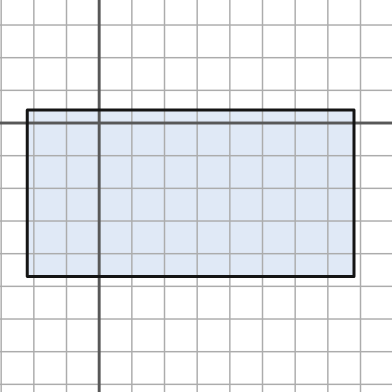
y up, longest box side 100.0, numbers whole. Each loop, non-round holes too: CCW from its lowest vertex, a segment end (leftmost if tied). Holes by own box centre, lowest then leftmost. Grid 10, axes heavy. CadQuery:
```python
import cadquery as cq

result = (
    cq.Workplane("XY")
    .moveTo(-22.0, -47.0)
    .lineTo(78.0, -47.0)
    .lineTo(78.0, 4.0)
    .lineTo(-22.0, 4.0)
    .close()
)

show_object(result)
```